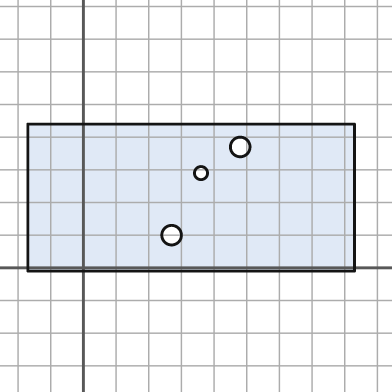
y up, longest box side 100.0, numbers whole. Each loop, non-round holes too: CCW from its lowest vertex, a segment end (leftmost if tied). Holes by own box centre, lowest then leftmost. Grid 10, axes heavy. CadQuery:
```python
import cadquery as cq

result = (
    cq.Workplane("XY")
    .moveTo(-17.0, -1.0)
    .lineTo(83.0, -1.0)
    .lineTo(83.0, 44.0)
    .lineTo(-17.0, 44.0)
    .close()
    .moveTo(27.0, 10.0)
    .circle(3.0)
    .moveTo(36.0, 29.0)
    .circle(2.0)
    .moveTo(48.0, 37.0)
    .circle(3.0)
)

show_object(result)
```